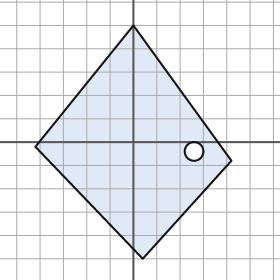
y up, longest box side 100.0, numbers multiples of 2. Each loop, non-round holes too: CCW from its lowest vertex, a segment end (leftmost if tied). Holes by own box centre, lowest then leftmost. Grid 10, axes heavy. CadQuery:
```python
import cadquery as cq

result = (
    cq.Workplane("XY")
    .moveTo(4.0, -50.0)
    .lineTo(42.0, -8.0)
    .lineTo(0.0, 50.0)
    .lineTo(-42.0, -2.0)
    .close()
    .moveTo(26.0, -4.0)
    .circle(4.0)
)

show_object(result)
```